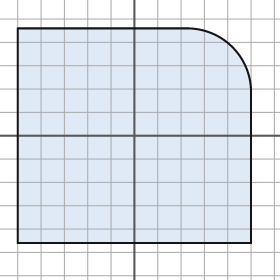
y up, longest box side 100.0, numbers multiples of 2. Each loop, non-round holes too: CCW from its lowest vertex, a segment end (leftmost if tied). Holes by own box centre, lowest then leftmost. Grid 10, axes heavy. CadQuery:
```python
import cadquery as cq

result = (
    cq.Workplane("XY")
    .moveTo(-50.0, -46.0)
    .lineTo(50.0, -46.0)
    .lineTo(50.0, 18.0)
    .threePointArc((42.0, 38.0), (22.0, 46.0))
    .lineTo(-50.0, 46.0)
    .close()
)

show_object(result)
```